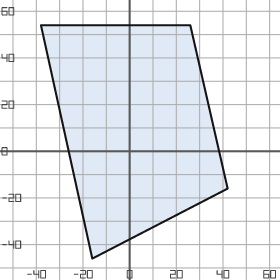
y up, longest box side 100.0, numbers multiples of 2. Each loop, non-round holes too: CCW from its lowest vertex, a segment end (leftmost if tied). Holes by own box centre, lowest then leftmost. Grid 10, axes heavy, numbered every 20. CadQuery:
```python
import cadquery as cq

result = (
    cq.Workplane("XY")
    .moveTo(-16.0, -46.0)
    .lineTo(42.0, -16.0)
    .lineTo(26.0, 54.0)
    .lineTo(-38.0, 54.0)
    .close()
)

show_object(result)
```